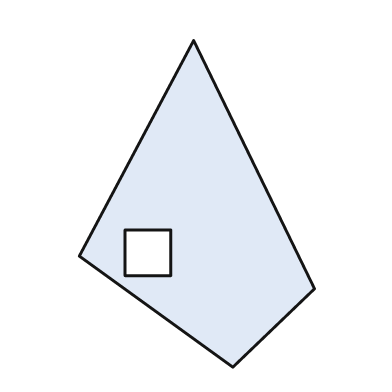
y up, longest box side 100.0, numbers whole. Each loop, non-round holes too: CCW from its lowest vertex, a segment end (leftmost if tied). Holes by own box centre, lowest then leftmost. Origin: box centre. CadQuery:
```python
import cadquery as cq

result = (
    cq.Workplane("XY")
    .moveTo(11.0, -50.0)
    .lineTo(36.0, -26.0)
    .lineTo(-1.0, 50.0)
    .lineTo(-36.0, -16.0)
    .close()
    .moveTo(-22.0, -22.0)
    .lineTo(-8.0, -22.0)
    .lineTo(-8.0, -8.0)
    .lineTo(-22.0, -8.0)
    .close()
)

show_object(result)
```